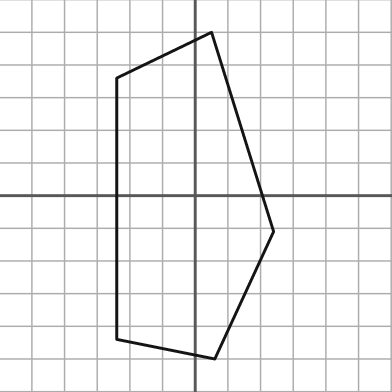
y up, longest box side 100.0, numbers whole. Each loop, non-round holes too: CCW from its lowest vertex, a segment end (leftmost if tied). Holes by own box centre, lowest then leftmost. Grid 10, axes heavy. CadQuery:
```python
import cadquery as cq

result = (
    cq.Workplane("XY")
    .moveTo(6.0, -50.0)
    .lineTo(24.0, -11.0)
    .lineTo(5.0, 50.0)
    .lineTo(-24.0, 36.0)
    .lineTo(-24.0, -44.0)
    .close()
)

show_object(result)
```